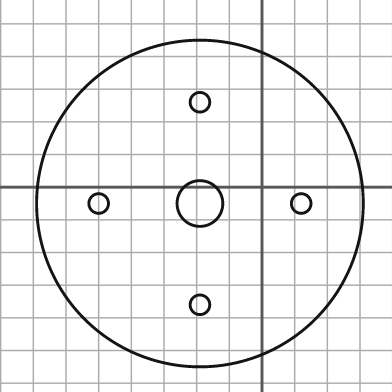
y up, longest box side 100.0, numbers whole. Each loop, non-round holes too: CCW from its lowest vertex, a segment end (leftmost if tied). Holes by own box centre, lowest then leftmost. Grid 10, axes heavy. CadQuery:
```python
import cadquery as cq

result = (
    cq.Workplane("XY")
    .moveTo(-19.0, -5.0)
    .circle(50.0)
    .moveTo(-19.0, -36.0)
    .circle(3.0)
    .moveTo(-50.0, -5.0)
    .circle(3.0)
    .moveTo(-19.0, -5.0)
    .circle(7.0)
    .moveTo(12.0, -5.0)
    .circle(3.0)
    .moveTo(-19.0, 26.0)
    .circle(3.0)
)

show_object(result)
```